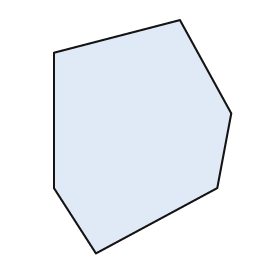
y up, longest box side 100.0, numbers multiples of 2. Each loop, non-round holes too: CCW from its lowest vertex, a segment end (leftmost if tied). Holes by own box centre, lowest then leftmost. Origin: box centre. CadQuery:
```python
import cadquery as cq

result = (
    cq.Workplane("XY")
    .moveTo(-20.0, -50.0)
    .lineTo(32.0, -22.0)
    .lineTo(38.0, 10.0)
    .lineTo(16.0, 50.0)
    .lineTo(-38.0, 36.0)
    .lineTo(-38.0, -22.0)
    .close()
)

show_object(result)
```